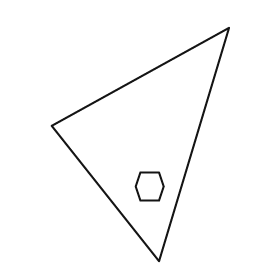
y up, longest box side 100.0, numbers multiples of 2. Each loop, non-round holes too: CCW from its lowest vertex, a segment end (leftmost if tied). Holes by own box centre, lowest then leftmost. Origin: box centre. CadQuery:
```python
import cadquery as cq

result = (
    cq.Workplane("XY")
    .moveTo(8.0, -50.0)
    .lineTo(38.0, 50.0)
    .lineTo(-38.0, 8.0)
    .close()
    .moveTo(0.0, -24.0)
    .lineTo(8.0, -24.0)
    .lineTo(10.0, -18.0)
    .lineTo(8.0, -12.0)
    .lineTo(0.0, -12.0)
    .lineTo(-2.0, -18.0)
    .close()
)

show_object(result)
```